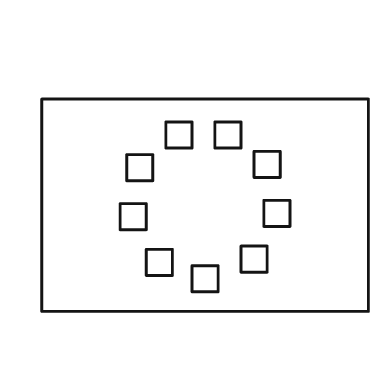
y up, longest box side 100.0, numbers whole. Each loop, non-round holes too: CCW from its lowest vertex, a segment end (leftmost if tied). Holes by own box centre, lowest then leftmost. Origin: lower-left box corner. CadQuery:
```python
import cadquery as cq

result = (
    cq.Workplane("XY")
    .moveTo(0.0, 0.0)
    .lineTo(100.0, 0.0)
    .lineTo(100.0, 65.0)
    .lineTo(0.0, 65.0)
    .close()
    .moveTo(46.0, 6.0)
    .lineTo(54.0, 6.0)
    .lineTo(54.0, 14.0)
    .lineTo(46.0, 14.0)
    .close()
    .moveTo(32.0, 11.0)
    .lineTo(40.0, 11.0)
    .lineTo(40.0, 19.0)
    .lineTo(32.0, 19.0)
    .close()
    .moveTo(61.0, 12.0)
    .lineTo(69.0, 12.0)
    .lineTo(69.0, 20.0)
    .lineTo(61.0, 20.0)
    .close()
    .moveTo(24.0, 25.0)
    .lineTo(32.0, 25.0)
    .lineTo(32.0, 33.0)
    .lineTo(24.0, 33.0)
    .close()
    .moveTo(68.0, 26.0)
    .lineTo(76.0, 26.0)
    .lineTo(76.0, 34.0)
    .lineTo(68.0, 34.0)
    .close()
    .moveTo(26.0, 40.0)
    .lineTo(34.0, 40.0)
    .lineTo(34.0, 48.0)
    .lineTo(26.0, 48.0)
    .close()
    .moveTo(65.0, 41.0)
    .lineTo(73.0, 41.0)
    .lineTo(73.0, 49.0)
    .lineTo(65.0, 49.0)
    .close()
    .moveTo(38.0, 50.0)
    .lineTo(46.0, 50.0)
    .lineTo(46.0, 58.0)
    .lineTo(38.0, 58.0)
    .close()
    .moveTo(53.0, 50.0)
    .lineTo(61.0, 50.0)
    .lineTo(61.0, 58.0)
    .lineTo(53.0, 58.0)
    .close()
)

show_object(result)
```